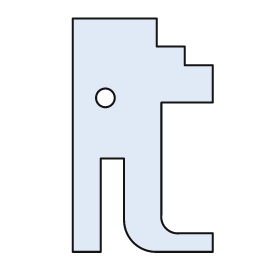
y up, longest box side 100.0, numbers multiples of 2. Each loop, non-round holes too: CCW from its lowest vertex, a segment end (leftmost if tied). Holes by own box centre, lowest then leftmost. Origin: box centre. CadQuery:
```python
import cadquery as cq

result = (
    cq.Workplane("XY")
    .moveTo(-30.0, -50.0)
    .lineTo(-18.0, -50.0)
    .lineTo(-18.0, -10.0)
    .lineTo(-8.0, -10.0)
    .lineTo(-8.0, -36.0)
    .threePointArc((-4.0, -46.0), (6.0, -50.0))
    .lineTo(30.0, -50.0)
    .lineTo(30.0, -42.0)
    .lineTo(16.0, -42.0)
    .threePointArc((10.0, -40.0), (8.0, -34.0))
    .lineTo(8.0, 14.0)
    .lineTo(30.0, 14.0)
    .lineTo(30.0, 30.0)
    .lineTo(18.0, 30.0)
    .lineTo(18.0, 38.0)
    .lineTo(6.0, 38.0)
    .lineTo(6.0, 50.0)
    .lineTo(-30.0, 50.0)
    .close()
    .moveTo(-16.0, 16.0)
    .circle(4.0)
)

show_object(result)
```